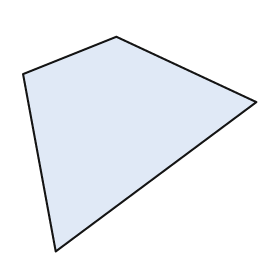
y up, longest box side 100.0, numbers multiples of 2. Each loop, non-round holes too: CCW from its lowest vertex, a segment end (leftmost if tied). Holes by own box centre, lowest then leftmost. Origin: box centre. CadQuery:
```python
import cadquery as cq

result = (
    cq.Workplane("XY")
    .moveTo(-36.0, -46.0)
    .lineTo(50.0, 18.0)
    .lineTo(-10.0, 46.0)
    .lineTo(-50.0, 30.0)
    .close()
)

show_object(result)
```